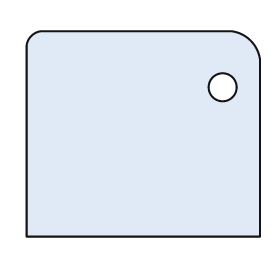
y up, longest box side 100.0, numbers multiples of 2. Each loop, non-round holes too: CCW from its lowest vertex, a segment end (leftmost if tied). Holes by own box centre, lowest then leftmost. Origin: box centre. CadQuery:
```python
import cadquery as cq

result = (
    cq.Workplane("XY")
    .moveTo(-50.0, -44.0)
    .lineTo(50.0, -44.0)
    .lineTo(50.0, 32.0)
    .threePointArc((46.0, 40.0), (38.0, 44.0))
    .lineTo(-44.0, 44.0)
    .threePointArc((-48.0, 42.0), (-50.0, 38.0))
    .close()
    .moveTo(34.0, 20.0)
    .circle(6.0)
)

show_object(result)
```